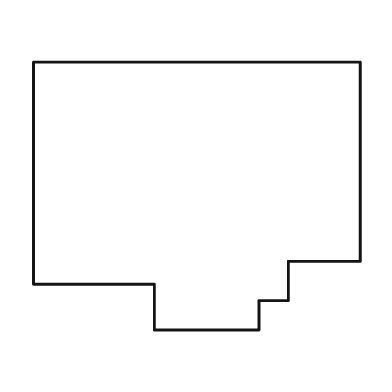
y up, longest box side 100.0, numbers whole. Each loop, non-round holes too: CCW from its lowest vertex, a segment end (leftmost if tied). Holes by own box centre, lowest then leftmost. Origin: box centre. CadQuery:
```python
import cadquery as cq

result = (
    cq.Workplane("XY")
    .moveTo(-13.0, -41.0)
    .lineTo(19.0, -41.0)
    .lineTo(19.0, -32.0)
    .lineTo(28.0, -32.0)
    .lineTo(28.0, -20.0)
    .lineTo(50.0, -20.0)
    .lineTo(50.0, 41.0)
    .lineTo(-50.0, 41.0)
    .lineTo(-50.0, -27.0)
    .lineTo(-13.0, -27.0)
    .close()
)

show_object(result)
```